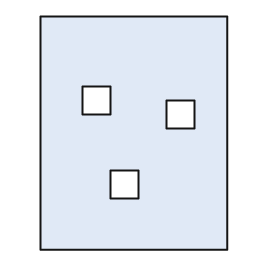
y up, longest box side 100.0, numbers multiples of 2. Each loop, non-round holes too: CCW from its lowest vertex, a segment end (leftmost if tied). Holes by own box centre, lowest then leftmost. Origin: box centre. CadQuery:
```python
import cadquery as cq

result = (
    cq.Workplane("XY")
    .moveTo(-40.0, -50.0)
    .lineTo(40.0, -50.0)
    .lineTo(40.0, 50.0)
    .lineTo(-40.0, 50.0)
    .close()
    .moveTo(-10.0, -28.0)
    .lineTo(2.0, -28.0)
    .lineTo(2.0, -16.0)
    .lineTo(-10.0, -16.0)
    .close()
    .moveTo(14.0, 2.0)
    .lineTo(26.0, 2.0)
    .lineTo(26.0, 14.0)
    .lineTo(14.0, 14.0)
    .close()
    .moveTo(-22.0, 8.0)
    .lineTo(-10.0, 8.0)
    .lineTo(-10.0, 20.0)
    .lineTo(-22.0, 20.0)
    .close()
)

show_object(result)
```